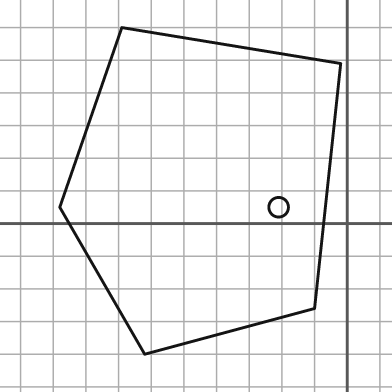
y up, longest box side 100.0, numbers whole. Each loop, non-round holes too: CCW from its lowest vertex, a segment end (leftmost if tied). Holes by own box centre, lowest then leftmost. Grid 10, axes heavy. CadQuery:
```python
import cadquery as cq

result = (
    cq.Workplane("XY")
    .moveTo(-62.0, -40.0)
    .lineTo(-10.0, -26.0)
    .lineTo(-2.0, 49.0)
    .lineTo(-69.0, 60.0)
    .lineTo(-88.0, 5.0)
    .close()
    .moveTo(-21.0, 5.0)
    .circle(3.0)
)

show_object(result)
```